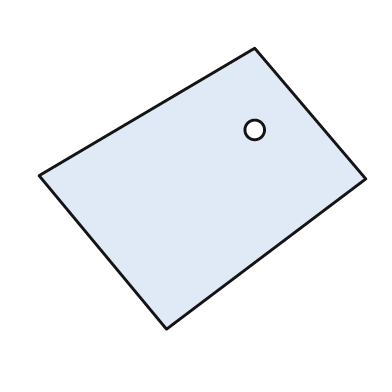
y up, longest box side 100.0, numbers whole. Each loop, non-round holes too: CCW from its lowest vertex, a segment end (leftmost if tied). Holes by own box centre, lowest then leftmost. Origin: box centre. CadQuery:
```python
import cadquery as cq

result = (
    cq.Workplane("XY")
    .moveTo(-11.0, -43.0)
    .lineTo(50.0, 3.0)
    .lineTo(16.0, 43.0)
    .lineTo(-50.0, 4.0)
    .close()
    .moveTo(16.0, 18.0)
    .circle(3.0)
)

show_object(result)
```